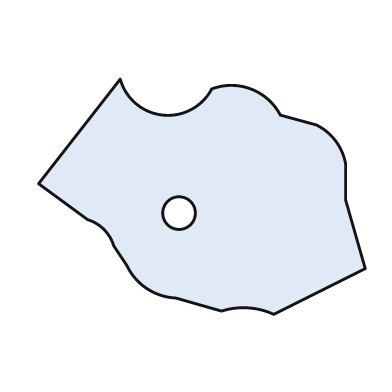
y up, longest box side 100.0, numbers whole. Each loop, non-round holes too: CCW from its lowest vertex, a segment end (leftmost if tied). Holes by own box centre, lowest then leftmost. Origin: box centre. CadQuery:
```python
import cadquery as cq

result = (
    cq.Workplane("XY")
    .moveTo(22.0, -36.0)
    .lineTo(50.0, -22.0)
    .lineTo(44.0, -1.0)
    .lineTo(44.0, 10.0)
    .threePointArc((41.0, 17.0), (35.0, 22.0))
    .lineTo(24.0, 25.0)
    .threePointArc((15.0, 33.0), (3.0, 33.0))
    .threePointArc((-12.0, 25.0), (-25.0, 36.0))
    .lineTo(-50.0, 4.0)
    .lineTo(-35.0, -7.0)
    .threePointArc((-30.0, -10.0), (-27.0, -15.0))
    .lineTo(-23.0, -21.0)
    .threePointArc((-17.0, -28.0), (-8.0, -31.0))
    .lineTo(6.0, -35.0)
    .threePointArc((14.0, -34.0), (22.0, -36.0))
    .close()
    .moveTo(-7.0, -5.0)
    .circle(5.0)
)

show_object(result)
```